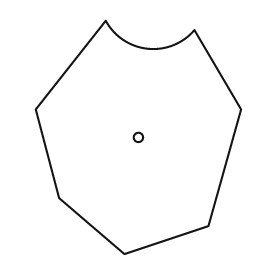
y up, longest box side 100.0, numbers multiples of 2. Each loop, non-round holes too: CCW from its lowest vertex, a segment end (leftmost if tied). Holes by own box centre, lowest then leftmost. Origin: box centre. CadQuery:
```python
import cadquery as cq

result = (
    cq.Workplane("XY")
    .moveTo(-6.0, -50.0)
    .lineTo(30.0, -38.0)
    .lineTo(44.0, 12.0)
    .lineTo(24.0, 46.0)
    .threePointArc((4.0, 38.0), (-14.0, 50.0))
    .lineTo(-44.0, 12.0)
    .lineTo(-34.0, -26.0)
    .close()
    .moveTo(0.0, 0.0)
    .circle(2.0)
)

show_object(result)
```